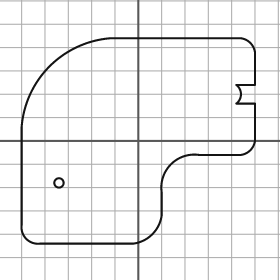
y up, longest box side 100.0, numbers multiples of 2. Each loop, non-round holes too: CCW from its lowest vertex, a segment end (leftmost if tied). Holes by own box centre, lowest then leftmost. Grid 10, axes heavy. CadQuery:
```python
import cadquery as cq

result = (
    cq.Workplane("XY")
    .moveTo(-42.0, -44.0)
    .lineTo(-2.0, -44.0)
    .threePointArc((6.0, -40.0), (10.0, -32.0))
    .lineTo(10.0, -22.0)
    .threePointArc((14.0, -10.0), (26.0, -6.0))
    .lineTo(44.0, -6.0)
    .threePointArc((48.0, -4.0), (50.0, 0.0))
    .lineTo(50.0, 16.0)
    .lineTo(42.0, 16.0)
    .threePointArc((44.0, 20.0), (42.0, 24.0))
    .lineTo(50.0, 24.0)
    .lineTo(50.0, 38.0)
    .threePointArc((48.0, 42.0), (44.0, 44.0))
    .lineTo(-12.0, 44.0)
    .threePointArc((-38.0, 32.0), (-50.0, 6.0))
    .lineTo(-50.0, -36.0)
    .threePointArc((-48.0, -42.0), (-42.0, -44.0))
    .close()
    .moveTo(-34.0, -18.0)
    .circle(2.0)
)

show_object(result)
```